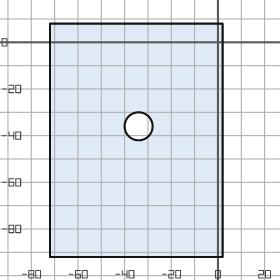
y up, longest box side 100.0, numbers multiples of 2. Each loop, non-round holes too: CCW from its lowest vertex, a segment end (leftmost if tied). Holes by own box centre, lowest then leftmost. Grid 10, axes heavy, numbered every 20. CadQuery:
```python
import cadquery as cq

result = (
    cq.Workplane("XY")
    .moveTo(-72.0, -92.0)
    .lineTo(2.0, -92.0)
    .lineTo(2.0, 8.0)
    .lineTo(-72.0, 8.0)
    .close()
    .moveTo(-34.0, -36.0)
    .circle(6.0)
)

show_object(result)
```